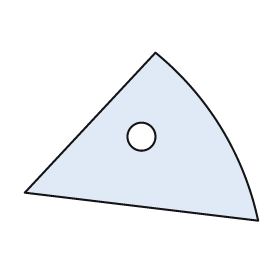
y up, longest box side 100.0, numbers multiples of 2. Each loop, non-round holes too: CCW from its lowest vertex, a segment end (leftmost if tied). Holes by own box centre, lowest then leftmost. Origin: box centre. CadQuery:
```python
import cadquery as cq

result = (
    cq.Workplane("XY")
    .moveTo(50.0, -36.0)
    .threePointArc((34.0, 4.0), (6.0, 36.0))
    .lineTo(-50.0, -24.0)
    .close()
    .moveTo(0.0, 0.0)
    .circle(6.0)
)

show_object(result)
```